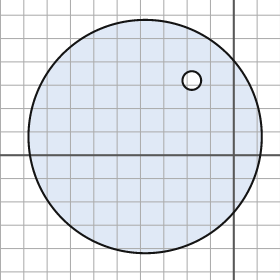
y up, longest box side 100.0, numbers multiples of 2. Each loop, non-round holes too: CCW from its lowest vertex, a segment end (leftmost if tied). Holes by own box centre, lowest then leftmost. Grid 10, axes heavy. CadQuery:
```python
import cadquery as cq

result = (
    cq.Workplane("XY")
    .moveTo(-38.0, 8.0)
    .circle(50.0)
    .moveTo(-18.0, 32.0)
    .circle(4.0)
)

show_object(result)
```